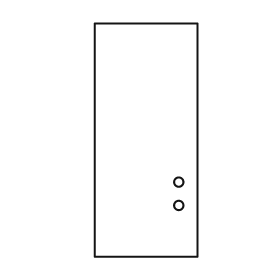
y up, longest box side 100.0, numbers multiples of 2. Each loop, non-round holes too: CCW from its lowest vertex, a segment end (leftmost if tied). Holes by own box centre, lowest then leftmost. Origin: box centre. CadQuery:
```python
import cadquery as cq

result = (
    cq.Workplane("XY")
    .moveTo(-22.0, -50.0)
    .lineTo(22.0, -50.0)
    .lineTo(22.0, 50.0)
    .lineTo(-22.0, 50.0)
    .close()
    .moveTo(14.0, -28.0)
    .circle(2.0)
    .moveTo(14.0, -18.0)
    .circle(2.0)
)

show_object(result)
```